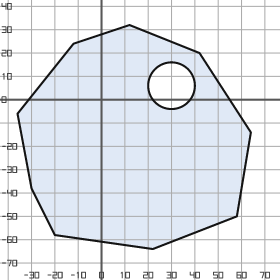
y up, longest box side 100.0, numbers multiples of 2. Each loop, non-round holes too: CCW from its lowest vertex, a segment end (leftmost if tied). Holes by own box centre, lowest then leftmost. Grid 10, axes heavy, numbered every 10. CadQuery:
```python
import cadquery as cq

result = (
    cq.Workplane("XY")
    .moveTo(22.0, -64.0)
    .lineTo(58.0, -50.0)
    .lineTo(64.0, -14.0)
    .lineTo(42.0, 20.0)
    .lineTo(12.0, 32.0)
    .lineTo(-12.0, 24.0)
    .lineTo(-36.0, -6.0)
    .lineTo(-30.0, -38.0)
    .lineTo(-20.0, -58.0)
    .close()
    .moveTo(30.0, 6.0)
    .circle(10.0)
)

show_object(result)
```